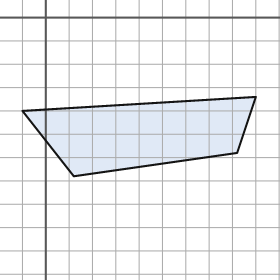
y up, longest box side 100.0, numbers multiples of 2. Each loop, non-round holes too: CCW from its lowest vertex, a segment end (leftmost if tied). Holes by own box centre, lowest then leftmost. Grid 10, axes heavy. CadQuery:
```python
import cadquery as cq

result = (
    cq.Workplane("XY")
    .moveTo(12.0, -68.0)
    .lineTo(82.0, -58.0)
    .lineTo(90.0, -34.0)
    .lineTo(-10.0, -40.0)
    .close()
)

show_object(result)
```